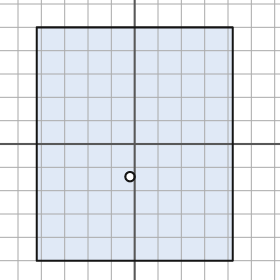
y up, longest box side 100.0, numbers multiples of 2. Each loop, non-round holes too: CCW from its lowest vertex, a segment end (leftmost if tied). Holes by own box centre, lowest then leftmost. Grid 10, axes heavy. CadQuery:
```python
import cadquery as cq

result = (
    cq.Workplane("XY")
    .moveTo(-42.0, -50.0)
    .lineTo(42.0, -50.0)
    .lineTo(42.0, 50.0)
    .lineTo(-42.0, 50.0)
    .close()
    .moveTo(-2.0, -14.0)
    .circle(2.0)
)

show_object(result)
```